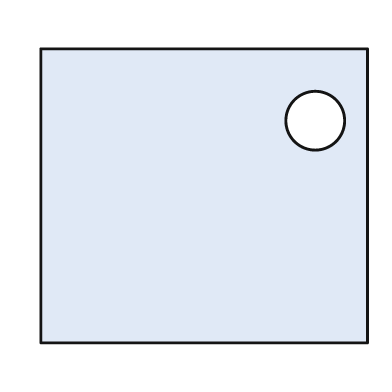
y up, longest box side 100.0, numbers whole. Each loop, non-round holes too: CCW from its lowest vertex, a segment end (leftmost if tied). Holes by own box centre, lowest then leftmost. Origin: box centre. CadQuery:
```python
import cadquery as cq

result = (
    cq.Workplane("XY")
    .moveTo(-50.0, -45.0)
    .lineTo(50.0, -45.0)
    .lineTo(50.0, 45.0)
    .lineTo(-50.0, 45.0)
    .close()
    .moveTo(34.0, 23.0)
    .circle(9.0)
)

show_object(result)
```